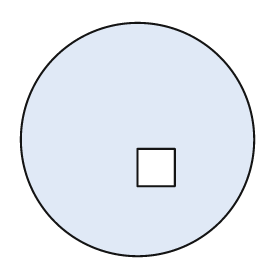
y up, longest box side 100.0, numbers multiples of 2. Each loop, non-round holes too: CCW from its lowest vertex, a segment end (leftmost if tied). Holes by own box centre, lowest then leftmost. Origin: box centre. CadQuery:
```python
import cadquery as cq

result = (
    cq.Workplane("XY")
    .moveTo(0.0, 0.0)
    .circle(50.0)
    .moveTo(0.0, -20.0)
    .lineTo(16.0, -20.0)
    .lineTo(16.0, -4.0)
    .lineTo(0.0, -4.0)
    .close()
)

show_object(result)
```